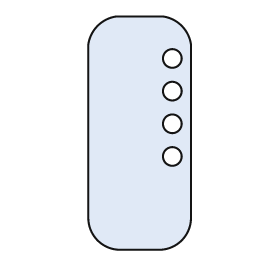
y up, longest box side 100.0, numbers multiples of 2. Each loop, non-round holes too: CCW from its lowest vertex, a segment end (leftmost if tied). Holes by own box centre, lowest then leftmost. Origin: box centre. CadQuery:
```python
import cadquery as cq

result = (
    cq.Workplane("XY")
    .moveTo(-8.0, -50.0)
    .lineTo(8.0, -50.0)
    .threePointArc((18.0, -46.0), (22.0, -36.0))
    .lineTo(22.0, 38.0)
    .threePointArc((18.0, 46.0), (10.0, 50.0))
    .lineTo(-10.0, 50.0)
    .threePointArc((-18.0, 46.0), (-22.0, 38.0))
    .lineTo(-22.0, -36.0)
    .threePointArc((-18.0, -46.0), (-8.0, -50.0))
    .close()
    .moveTo(14.0, -10.0)
    .circle(4.0)
    .moveTo(14.0, 4.0)
    .circle(4.0)
    .moveTo(14.0, 18.0)
    .circle(4.0)
    .moveTo(14.0, 32.0)
    .circle(4.0)
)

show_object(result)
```